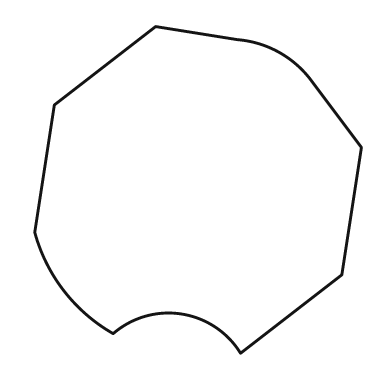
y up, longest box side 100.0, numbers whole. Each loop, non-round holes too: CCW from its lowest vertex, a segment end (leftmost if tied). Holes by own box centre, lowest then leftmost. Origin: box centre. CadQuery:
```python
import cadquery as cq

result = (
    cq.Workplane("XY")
    .moveTo(13.0, -50.0)
    .lineTo(44.0, -26.0)
    .lineTo(50.0, 13.0)
    .lineTo(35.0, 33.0)
    .threePointArc((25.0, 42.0), (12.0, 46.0))
    .lineTo(-13.0, 50.0)
    .lineTo(-44.0, 26.0)
    .lineTo(-50.0, -13.0)
    .threePointArc((-41.0, -31.0), (-26.0, -44.0))
    .threePointArc((-5.0, -38.0), (13.0, -50.0))
    .close()
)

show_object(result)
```